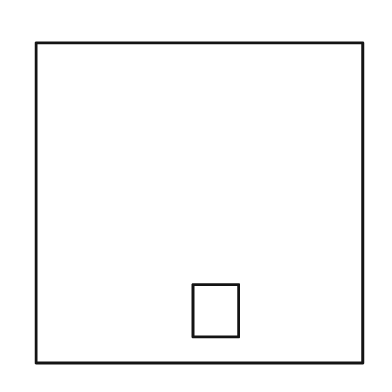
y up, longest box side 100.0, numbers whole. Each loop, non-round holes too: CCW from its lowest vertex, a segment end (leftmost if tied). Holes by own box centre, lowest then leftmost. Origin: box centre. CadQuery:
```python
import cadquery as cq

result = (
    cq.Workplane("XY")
    .moveTo(-50.0, -49.0)
    .lineTo(50.0, -49.0)
    .lineTo(50.0, 49.0)
    .lineTo(-50.0, 49.0)
    .close()
    .moveTo(-2.0, -41.0)
    .lineTo(12.0, -41.0)
    .lineTo(12.0, -25.0)
    .lineTo(-2.0, -25.0)
    .close()
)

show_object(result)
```